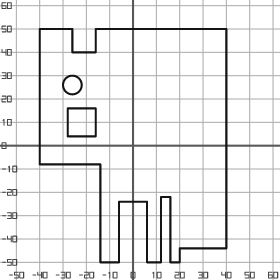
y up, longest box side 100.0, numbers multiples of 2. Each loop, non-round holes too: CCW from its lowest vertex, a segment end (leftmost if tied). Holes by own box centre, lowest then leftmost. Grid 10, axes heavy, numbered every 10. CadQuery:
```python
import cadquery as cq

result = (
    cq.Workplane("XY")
    .moveTo(-14.0, -50.0)
    .lineTo(-6.0, -50.0)
    .lineTo(-6.0, -24.0)
    .lineTo(6.0, -24.0)
    .lineTo(6.0, -50.0)
    .lineTo(12.0, -50.0)
    .lineTo(12.0, -22.0)
    .lineTo(16.0, -22.0)
    .lineTo(16.0, -50.0)
    .lineTo(20.0, -50.0)
    .lineTo(20.0, -44.0)
    .lineTo(40.0, -44.0)
    .lineTo(40.0, 50.0)
    .lineTo(-16.0, 50.0)
    .lineTo(-16.0, 40.0)
    .lineTo(-26.0, 40.0)
    .lineTo(-26.0, 50.0)
    .lineTo(-40.0, 50.0)
    .lineTo(-40.0, -8.0)
    .lineTo(-14.0, -8.0)
    .close()
    .moveTo(-28.0, 4.0)
    .lineTo(-16.0, 4.0)
    .lineTo(-16.0, 16.0)
    .lineTo(-28.0, 16.0)
    .close()
    .moveTo(-26.0, 26.0)
    .circle(4.0)
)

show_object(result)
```